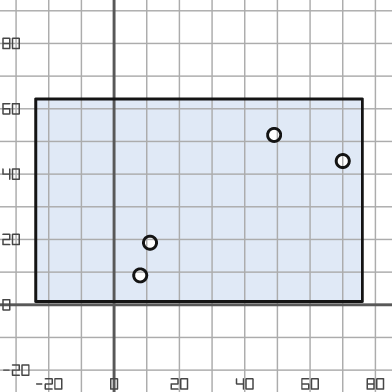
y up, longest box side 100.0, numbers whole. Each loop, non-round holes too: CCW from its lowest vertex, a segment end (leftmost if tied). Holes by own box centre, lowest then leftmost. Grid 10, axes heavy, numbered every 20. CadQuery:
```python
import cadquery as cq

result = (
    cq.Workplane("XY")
    .moveTo(-24.0, 1.0)
    .lineTo(76.0, 1.0)
    .lineTo(76.0, 63.0)
    .lineTo(-24.0, 63.0)
    .close()
    .moveTo(8.0, 9.0)
    .circle(2.0)
    .moveTo(11.0, 19.0)
    .circle(2.0)
    .moveTo(70.0, 44.0)
    .circle(2.0)
    .moveTo(49.0, 52.0)
    .circle(2.0)
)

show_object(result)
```